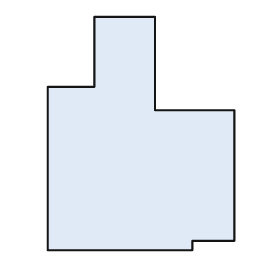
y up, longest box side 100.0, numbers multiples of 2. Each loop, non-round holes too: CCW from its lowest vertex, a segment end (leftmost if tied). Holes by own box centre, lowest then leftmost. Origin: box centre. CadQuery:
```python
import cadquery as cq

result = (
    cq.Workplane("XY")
    .moveTo(-40.0, -50.0)
    .lineTo(22.0, -50.0)
    .lineTo(22.0, -46.0)
    .lineTo(40.0, -46.0)
    .lineTo(40.0, 10.0)
    .lineTo(6.0, 10.0)
    .lineTo(6.0, 50.0)
    .lineTo(-20.0, 50.0)
    .lineTo(-20.0, 20.0)
    .lineTo(-40.0, 20.0)
    .close()
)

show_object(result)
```